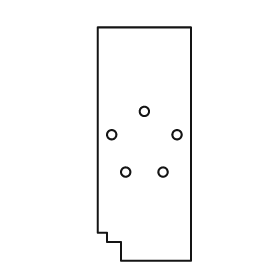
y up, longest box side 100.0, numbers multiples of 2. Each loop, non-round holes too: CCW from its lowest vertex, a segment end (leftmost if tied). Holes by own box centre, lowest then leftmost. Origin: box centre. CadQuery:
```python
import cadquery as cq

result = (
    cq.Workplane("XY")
    .moveTo(-10.0, -50.0)
    .lineTo(20.0, -50.0)
    .lineTo(20.0, 50.0)
    .lineTo(-20.0, 50.0)
    .lineTo(-20.0, -38.0)
    .lineTo(-16.0, -38.0)
    .lineTo(-16.0, -42.0)
    .lineTo(-10.0, -42.0)
    .close()
    .moveTo(-8.0, -12.0)
    .circle(2.0)
    .moveTo(8.0, -12.0)
    .circle(2.0)
    .moveTo(-14.0, 4.0)
    .circle(2.0)
    .moveTo(14.0, 4.0)
    .circle(2.0)
    .moveTo(0.0, 14.0)
    .circle(2.0)
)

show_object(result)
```